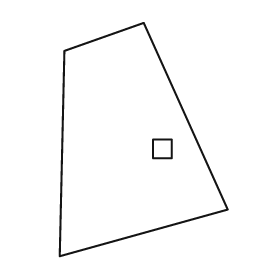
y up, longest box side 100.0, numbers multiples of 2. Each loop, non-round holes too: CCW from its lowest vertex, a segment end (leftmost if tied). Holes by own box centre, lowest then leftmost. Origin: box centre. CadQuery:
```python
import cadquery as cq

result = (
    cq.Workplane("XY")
    .moveTo(-36.0, -50.0)
    .lineTo(36.0, -30.0)
    .lineTo(0.0, 50.0)
    .lineTo(-34.0, 38.0)
    .close()
    .moveTo(4.0, -8.0)
    .lineTo(12.0, -8.0)
    .lineTo(12.0, 0.0)
    .lineTo(4.0, 0.0)
    .close()
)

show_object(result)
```